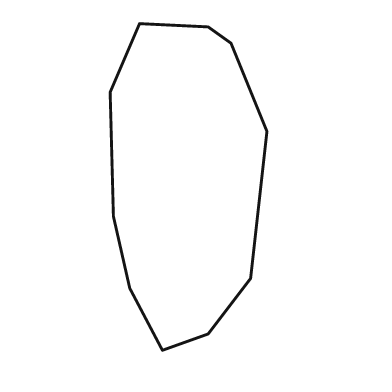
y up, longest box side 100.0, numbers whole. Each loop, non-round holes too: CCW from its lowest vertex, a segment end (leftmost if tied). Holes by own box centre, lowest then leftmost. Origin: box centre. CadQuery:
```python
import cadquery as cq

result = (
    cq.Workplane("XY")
    .moveTo(-8.0, -50.0)
    .lineTo(6.0, -45.0)
    .lineTo(19.0, -28.0)
    .lineTo(24.0, 17.0)
    .lineTo(13.0, 44.0)
    .lineTo(6.0, 49.0)
    .lineTo(-15.0, 50.0)
    .lineTo(-24.0, 29.0)
    .lineTo(-23.0, -9.0)
    .lineTo(-18.0, -31.0)
    .close()
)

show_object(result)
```